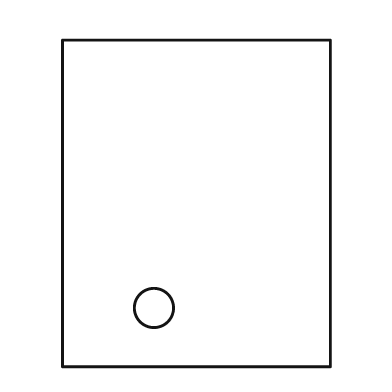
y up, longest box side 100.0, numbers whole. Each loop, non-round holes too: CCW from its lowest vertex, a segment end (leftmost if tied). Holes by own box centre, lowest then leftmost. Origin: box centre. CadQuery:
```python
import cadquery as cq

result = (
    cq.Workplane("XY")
    .moveTo(-41.0, -50.0)
    .lineTo(41.0, -50.0)
    .lineTo(41.0, 50.0)
    .lineTo(-41.0, 50.0)
    .close()
    .moveTo(-13.0, -32.0)
    .circle(6.0)
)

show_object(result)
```